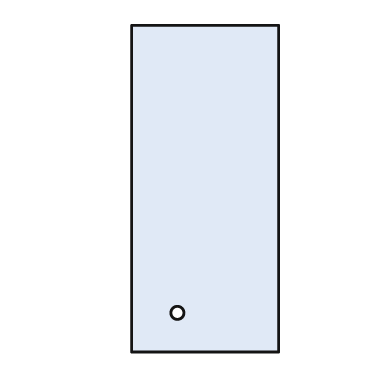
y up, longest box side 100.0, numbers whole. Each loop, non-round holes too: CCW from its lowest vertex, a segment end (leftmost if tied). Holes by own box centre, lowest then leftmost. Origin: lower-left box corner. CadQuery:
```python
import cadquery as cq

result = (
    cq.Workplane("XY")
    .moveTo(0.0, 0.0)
    .lineTo(45.0, 0.0)
    .lineTo(45.0, 100.0)
    .lineTo(0.0, 100.0)
    .close()
    .moveTo(14.0, 12.0)
    .circle(2.0)
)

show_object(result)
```